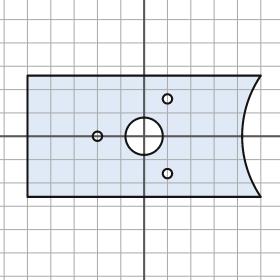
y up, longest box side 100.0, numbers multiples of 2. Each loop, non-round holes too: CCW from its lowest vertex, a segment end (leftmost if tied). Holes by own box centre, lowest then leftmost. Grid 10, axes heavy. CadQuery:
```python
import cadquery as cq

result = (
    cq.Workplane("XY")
    .moveTo(-50.0, -26.0)
    .lineTo(50.0, -26.0)
    .threePointArc((42.0, 0.0), (50.0, 26.0))
    .lineTo(-50.0, 26.0)
    .close()
    .moveTo(10.0, -16.0)
    .circle(2.0)
    .moveTo(-20.0, 0.0)
    .circle(2.0)
    .moveTo(0.0, 0.0)
    .circle(8.0)
    .moveTo(10.0, 16.0)
    .circle(2.0)
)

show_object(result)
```